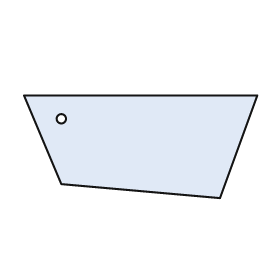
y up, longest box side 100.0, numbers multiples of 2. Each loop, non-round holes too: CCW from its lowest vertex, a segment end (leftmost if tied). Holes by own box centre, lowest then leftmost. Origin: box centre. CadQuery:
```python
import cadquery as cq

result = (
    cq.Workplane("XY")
    .moveTo(34.0, -22.0)
    .lineTo(50.0, 22.0)
    .lineTo(-50.0, 22.0)
    .lineTo(-34.0, -16.0)
    .close()
    .moveTo(-34.0, 12.0)
    .circle(2.0)
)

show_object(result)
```